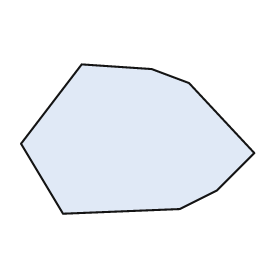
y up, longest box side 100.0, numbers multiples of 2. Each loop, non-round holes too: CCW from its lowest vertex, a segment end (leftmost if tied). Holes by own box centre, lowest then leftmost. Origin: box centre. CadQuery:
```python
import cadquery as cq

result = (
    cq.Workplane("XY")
    .moveTo(-32.0, -32.0)
    .lineTo(18.0, -30.0)
    .lineTo(34.0, -22.0)
    .lineTo(50.0, -6.0)
    .lineTo(22.0, 24.0)
    .lineTo(6.0, 30.0)
    .lineTo(-24.0, 32.0)
    .lineTo(-50.0, -2.0)
    .close()
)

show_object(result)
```